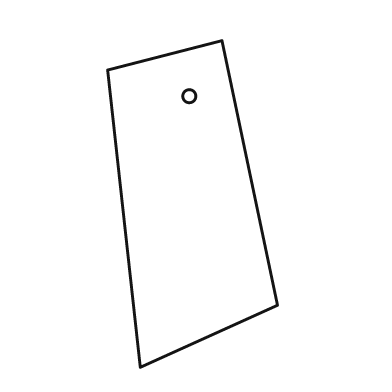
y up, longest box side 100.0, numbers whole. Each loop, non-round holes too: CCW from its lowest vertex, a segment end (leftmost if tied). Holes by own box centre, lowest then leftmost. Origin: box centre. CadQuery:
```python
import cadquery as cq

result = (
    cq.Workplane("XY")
    .moveTo(-16.0, -50.0)
    .lineTo(26.0, -31.0)
    .lineTo(9.0, 50.0)
    .lineTo(-26.0, 41.0)
    .close()
    .moveTo(-1.0, 33.0)
    .circle(2.0)
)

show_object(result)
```